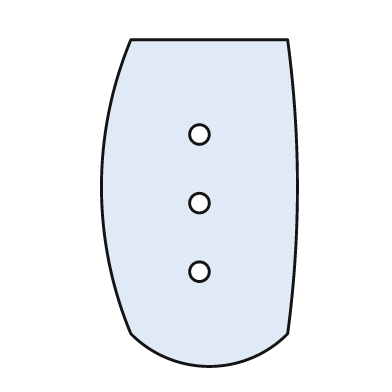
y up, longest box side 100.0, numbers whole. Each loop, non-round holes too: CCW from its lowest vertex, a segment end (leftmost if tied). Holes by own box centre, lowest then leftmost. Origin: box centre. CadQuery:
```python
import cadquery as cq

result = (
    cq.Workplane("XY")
    .moveTo(-21.0, -40.0)
    .threePointArc((3.0, -50.0), (27.0, -40.0))
    .threePointArc((30.0, 5.0), (27.0, 50.0))
    .lineTo(-21.0, 50.0)
    .threePointArc((-30.0, 5.0), (-21.0, -40.0))
    .close()
    .moveTo(0.0, -21.0)
    .circle(3.0)
    .moveTo(0.0, 0.0)
    .circle(3.0)
    .moveTo(0.0, 21.0)
    .circle(3.0)
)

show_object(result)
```